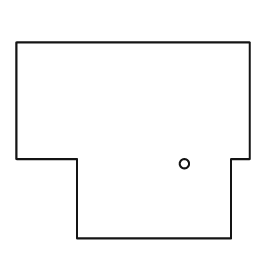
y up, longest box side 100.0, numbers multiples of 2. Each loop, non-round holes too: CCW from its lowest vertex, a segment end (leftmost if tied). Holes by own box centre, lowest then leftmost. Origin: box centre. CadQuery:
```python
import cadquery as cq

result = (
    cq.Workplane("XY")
    .moveTo(-24.0, -42.0)
    .lineTo(42.0, -42.0)
    .lineTo(42.0, -8.0)
    .lineTo(50.0, -8.0)
    .lineTo(50.0, 42.0)
    .lineTo(-50.0, 42.0)
    .lineTo(-50.0, -8.0)
    .lineTo(-24.0, -8.0)
    .close()
    .moveTo(22.0, -10.0)
    .circle(2.0)
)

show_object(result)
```